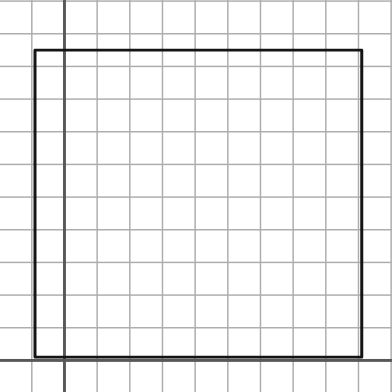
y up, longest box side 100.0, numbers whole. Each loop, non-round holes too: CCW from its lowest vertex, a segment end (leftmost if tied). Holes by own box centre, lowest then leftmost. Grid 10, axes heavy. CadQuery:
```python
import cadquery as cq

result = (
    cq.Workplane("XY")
    .moveTo(-9.0, 1.0)
    .lineTo(91.0, 1.0)
    .lineTo(91.0, 95.0)
    .lineTo(-9.0, 95.0)
    .close()
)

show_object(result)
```